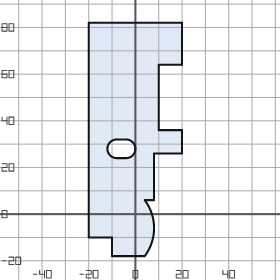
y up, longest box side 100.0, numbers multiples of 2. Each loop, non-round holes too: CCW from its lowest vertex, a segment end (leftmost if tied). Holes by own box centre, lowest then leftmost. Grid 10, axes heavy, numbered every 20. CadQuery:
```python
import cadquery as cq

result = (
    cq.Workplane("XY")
    .moveTo(-10.0, -18.0)
    .lineTo(4.0, -18.0)
    .threePointArc((8.0, -6.0), (4.0, 6.0))
    .lineTo(8.0, 6.0)
    .lineTo(8.0, 26.0)
    .lineTo(20.0, 26.0)
    .lineTo(20.0, 36.0)
    .lineTo(10.0, 36.0)
    .lineTo(10.0, 64.0)
    .lineTo(20.0, 64.0)
    .lineTo(20.0, 82.0)
    .lineTo(-20.0, 82.0)
    .lineTo(-20.0, -10.0)
    .lineTo(-10.0, -10.0)
    .close()
    .moveTo(-8.0, 24.0)
    .lineTo(-4.0, 24.0)
    .threePointArc((0.0, 28.0), (-4.0, 32.0))
    .lineTo(-8.0, 32.0)
    .threePointArc((-12.0, 28.0), (-8.0, 24.0))
    .close()
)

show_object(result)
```